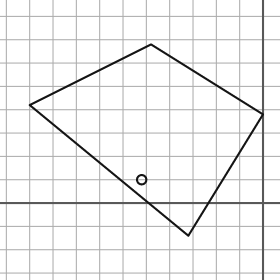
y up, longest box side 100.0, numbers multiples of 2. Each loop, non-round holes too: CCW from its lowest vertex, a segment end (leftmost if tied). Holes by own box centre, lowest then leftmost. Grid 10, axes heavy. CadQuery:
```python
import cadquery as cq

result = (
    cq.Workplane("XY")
    .moveTo(-32.0, -14.0)
    .lineTo(0.0, 38.0)
    .lineTo(-48.0, 68.0)
    .lineTo(-100.0, 42.0)
    .close()
    .moveTo(-52.0, 10.0)
    .circle(2.0)
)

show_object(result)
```